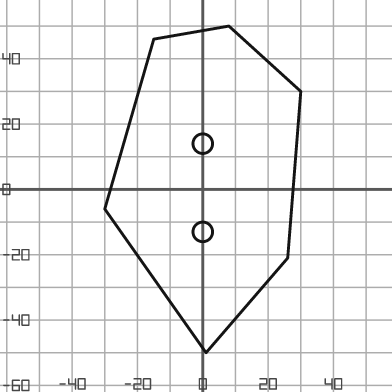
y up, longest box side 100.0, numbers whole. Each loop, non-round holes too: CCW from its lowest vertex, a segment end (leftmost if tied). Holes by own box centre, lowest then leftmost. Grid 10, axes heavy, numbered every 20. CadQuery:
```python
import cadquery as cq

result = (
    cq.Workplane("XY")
    .moveTo(1.0, -50.0)
    .lineTo(26.0, -21.0)
    .lineTo(30.0, 30.0)
    .lineTo(8.0, 50.0)
    .lineTo(-15.0, 46.0)
    .lineTo(-30.0, -6.0)
    .close()
    .moveTo(0.0, -13.0)
    .circle(3.0)
    .moveTo(0.0, 14.0)
    .circle(3.0)
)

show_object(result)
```